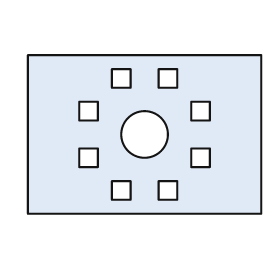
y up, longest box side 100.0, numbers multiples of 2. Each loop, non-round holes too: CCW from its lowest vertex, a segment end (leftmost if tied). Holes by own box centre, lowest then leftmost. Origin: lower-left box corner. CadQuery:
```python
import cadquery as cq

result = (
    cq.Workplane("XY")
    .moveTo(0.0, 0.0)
    .lineTo(100.0, 0.0)
    .lineTo(100.0, 68.0)
    .lineTo(0.0, 68.0)
    .close()
    .moveTo(36.0, 6.0)
    .lineTo(44.0, 6.0)
    .lineTo(44.0, 14.0)
    .lineTo(36.0, 14.0)
    .close()
    .moveTo(56.0, 6.0)
    .lineTo(64.0, 6.0)
    .lineTo(64.0, 14.0)
    .lineTo(56.0, 14.0)
    .close()
    .moveTo(22.0, 20.0)
    .lineTo(30.0, 20.0)
    .lineTo(30.0, 28.0)
    .lineTo(22.0, 28.0)
    .close()
    .moveTo(70.0, 20.0)
    .lineTo(78.0, 20.0)
    .lineTo(78.0, 28.0)
    .lineTo(70.0, 28.0)
    .close()
    .moveTo(50.0, 34.0)
    .circle(10.0)
    .moveTo(22.0, 40.0)
    .lineTo(30.0, 40.0)
    .lineTo(30.0, 48.0)
    .lineTo(22.0, 48.0)
    .close()
    .moveTo(70.0, 40.0)
    .lineTo(78.0, 40.0)
    .lineTo(78.0, 48.0)
    .lineTo(70.0, 48.0)
    .close()
    .moveTo(36.0, 54.0)
    .lineTo(44.0, 54.0)
    .lineTo(44.0, 62.0)
    .lineTo(36.0, 62.0)
    .close()
    .moveTo(56.0, 54.0)
    .lineTo(64.0, 54.0)
    .lineTo(64.0, 62.0)
    .lineTo(56.0, 62.0)
    .close()
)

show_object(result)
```